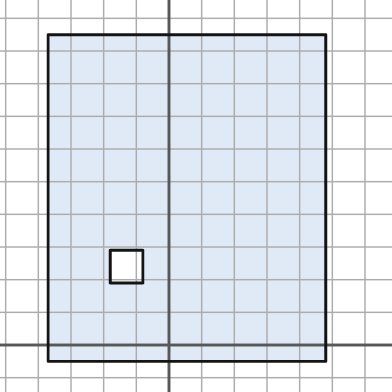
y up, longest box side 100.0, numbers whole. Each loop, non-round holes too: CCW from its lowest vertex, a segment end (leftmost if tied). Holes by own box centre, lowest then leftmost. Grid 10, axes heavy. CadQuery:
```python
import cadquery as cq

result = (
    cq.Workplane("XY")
    .moveTo(-37.0, -5.0)
    .lineTo(48.0, -5.0)
    .lineTo(48.0, 95.0)
    .lineTo(-37.0, 95.0)
    .close()
    .moveTo(-18.0, 19.0)
    .lineTo(-8.0, 19.0)
    .lineTo(-8.0, 29.0)
    .lineTo(-18.0, 29.0)
    .close()
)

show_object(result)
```